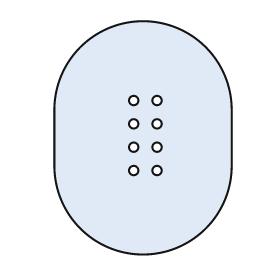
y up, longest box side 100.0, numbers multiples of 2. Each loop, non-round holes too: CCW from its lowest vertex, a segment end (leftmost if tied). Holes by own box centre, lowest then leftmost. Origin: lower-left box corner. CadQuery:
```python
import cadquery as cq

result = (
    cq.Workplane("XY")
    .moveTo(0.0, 38.0)
    .threePointArc((38.0, 0.0), (76.0, 38.0))
    .lineTo(76.0, 62.0)
    .threePointArc((38.0, 100.0), (0.0, 62.0))
    .close()
    .moveTo(34.0, 36.0)
    .circle(2.0)
    .moveTo(44.0, 36.0)
    .circle(2.0)
    .moveTo(34.0, 46.0)
    .circle(2.0)
    .moveTo(44.0, 46.0)
    .circle(2.0)
    .moveTo(34.0, 56.0)
    .circle(2.0)
    .moveTo(44.0, 56.0)
    .circle(2.0)
    .moveTo(34.0, 66.0)
    .circle(2.0)
    .moveTo(44.0, 66.0)
    .circle(2.0)
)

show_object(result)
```